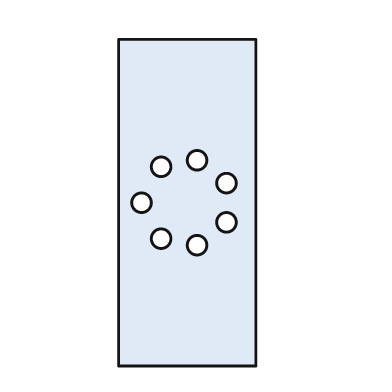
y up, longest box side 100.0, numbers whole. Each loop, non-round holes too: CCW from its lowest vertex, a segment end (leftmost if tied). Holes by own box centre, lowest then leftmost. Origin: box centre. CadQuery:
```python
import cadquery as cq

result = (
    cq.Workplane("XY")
    .moveTo(-21.0, -50.0)
    .lineTo(21.0, -50.0)
    .lineTo(21.0, 50.0)
    .lineTo(-21.0, 50.0)
    .close()
    .moveTo(3.0, -13.0)
    .circle(3.0)
    .moveTo(-8.0, -11.0)
    .circle(3.0)
    .moveTo(12.0, -6.0)
    .circle(3.0)
    .moveTo(-14.0, 0.0)
    .circle(3.0)
    .moveTo(12.0, 6.0)
    .circle(3.0)
    .moveTo(-8.0, 11.0)
    .circle(3.0)
    .moveTo(3.0, 13.0)
    .circle(3.0)
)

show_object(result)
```